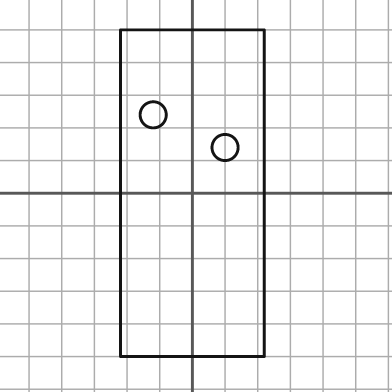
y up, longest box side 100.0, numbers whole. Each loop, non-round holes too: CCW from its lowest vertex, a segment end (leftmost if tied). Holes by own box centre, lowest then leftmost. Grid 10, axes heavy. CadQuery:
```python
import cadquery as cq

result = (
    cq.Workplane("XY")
    .moveTo(-22.0, -50.0)
    .lineTo(22.0, -50.0)
    .lineTo(22.0, 50.0)
    .lineTo(-22.0, 50.0)
    .close()
    .moveTo(10.0, 14.0)
    .circle(4.0)
    .moveTo(-12.0, 24.0)
    .circle(4.0)
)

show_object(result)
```